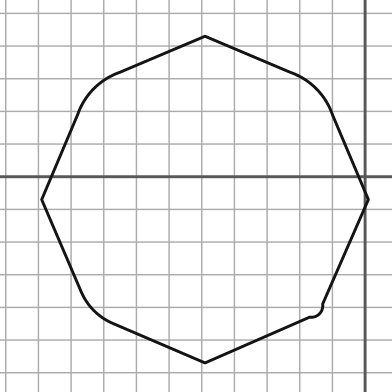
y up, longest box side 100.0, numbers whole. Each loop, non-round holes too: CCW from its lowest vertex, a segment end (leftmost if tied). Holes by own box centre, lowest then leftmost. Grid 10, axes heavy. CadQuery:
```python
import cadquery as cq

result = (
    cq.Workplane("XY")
    .moveTo(-49.0, -57.0)
    .lineTo(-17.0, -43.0)
    .threePointArc((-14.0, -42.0), (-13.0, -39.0))
    .lineTo(1.0, -7.0)
    .lineTo(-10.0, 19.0)
    .threePointArc((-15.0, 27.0), (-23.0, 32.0))
    .lineTo(-49.0, 43.0)
    .lineTo(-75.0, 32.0)
    .threePointArc((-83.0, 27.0), (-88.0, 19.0))
    .lineTo(-99.0, -7.0)
    .lineTo(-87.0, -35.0)
    .threePointArc((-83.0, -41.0), (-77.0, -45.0))
    .close()
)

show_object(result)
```